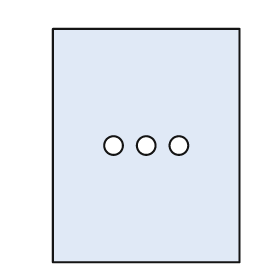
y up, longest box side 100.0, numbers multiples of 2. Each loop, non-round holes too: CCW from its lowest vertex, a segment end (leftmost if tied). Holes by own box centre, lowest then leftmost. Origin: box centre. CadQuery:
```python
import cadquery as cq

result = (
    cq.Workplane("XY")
    .moveTo(-40.0, -50.0)
    .lineTo(40.0, -50.0)
    .lineTo(40.0, 50.0)
    .lineTo(-40.0, 50.0)
    .close()
    .moveTo(-14.0, 0.0)
    .circle(4.0)
    .moveTo(0.0, 0.0)
    .circle(4.0)
    .moveTo(14.0, 0.0)
    .circle(4.0)
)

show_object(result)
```